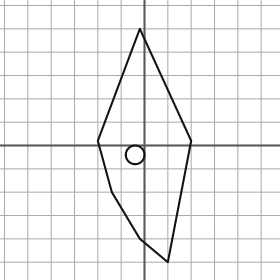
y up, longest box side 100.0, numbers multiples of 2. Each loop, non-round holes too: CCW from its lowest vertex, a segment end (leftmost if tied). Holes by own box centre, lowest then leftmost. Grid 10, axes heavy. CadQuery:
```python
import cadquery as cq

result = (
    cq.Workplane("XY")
    .moveTo(10.0, -50.0)
    .lineTo(20.0, 2.0)
    .lineTo(-2.0, 50.0)
    .lineTo(-20.0, 2.0)
    .lineTo(-14.0, -20.0)
    .lineTo(-2.0, -40.0)
    .close()
    .moveTo(-4.0, -4.0)
    .circle(4.0)
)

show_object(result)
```